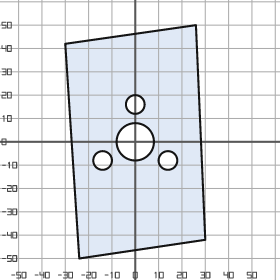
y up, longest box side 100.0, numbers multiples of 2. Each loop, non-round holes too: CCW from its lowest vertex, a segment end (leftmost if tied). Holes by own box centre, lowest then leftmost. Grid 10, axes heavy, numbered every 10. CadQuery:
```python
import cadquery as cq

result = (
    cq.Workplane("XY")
    .moveTo(-24.0, -50.0)
    .lineTo(30.0, -42.0)
    .lineTo(26.0, 50.0)
    .lineTo(-30.0, 42.0)
    .close()
    .moveTo(-14.0, -8.0)
    .circle(4.0)
    .moveTo(14.0, -8.0)
    .circle(4.0)
    .moveTo(0.0, 0.0)
    .circle(8.0)
    .moveTo(0.0, 16.0)
    .circle(4.0)
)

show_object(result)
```